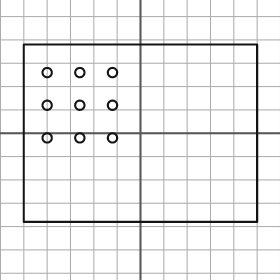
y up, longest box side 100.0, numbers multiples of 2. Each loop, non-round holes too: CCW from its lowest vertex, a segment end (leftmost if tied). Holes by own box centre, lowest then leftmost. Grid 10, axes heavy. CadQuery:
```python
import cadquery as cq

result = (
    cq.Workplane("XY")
    .moveTo(-50.0, -38.0)
    .lineTo(50.0, -38.0)
    .lineTo(50.0, 38.0)
    .lineTo(-50.0, 38.0)
    .close()
    .moveTo(-40.0, -2.0)
    .circle(2.0)
    .moveTo(-26.0, -2.0)
    .circle(2.0)
    .moveTo(-12.0, -2.0)
    .circle(2.0)
    .moveTo(-40.0, 12.0)
    .circle(2.0)
    .moveTo(-26.0, 12.0)
    .circle(2.0)
    .moveTo(-12.0, 12.0)
    .circle(2.0)
    .moveTo(-40.0, 26.0)
    .circle(2.0)
    .moveTo(-26.0, 26.0)
    .circle(2.0)
    .moveTo(-12.0, 26.0)
    .circle(2.0)
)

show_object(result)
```